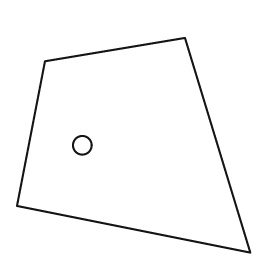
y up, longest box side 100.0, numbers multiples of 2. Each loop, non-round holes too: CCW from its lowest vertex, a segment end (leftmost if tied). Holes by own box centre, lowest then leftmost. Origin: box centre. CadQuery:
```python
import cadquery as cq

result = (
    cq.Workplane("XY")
    .moveTo(50.0, -46.0)
    .lineTo(22.0, 46.0)
    .lineTo(-38.0, 36.0)
    .lineTo(-50.0, -26.0)
    .close()
    .moveTo(-22.0, 0.0)
    .circle(4.0)
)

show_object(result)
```